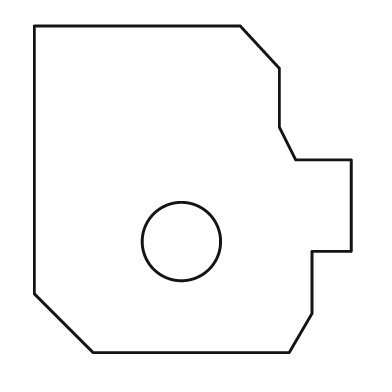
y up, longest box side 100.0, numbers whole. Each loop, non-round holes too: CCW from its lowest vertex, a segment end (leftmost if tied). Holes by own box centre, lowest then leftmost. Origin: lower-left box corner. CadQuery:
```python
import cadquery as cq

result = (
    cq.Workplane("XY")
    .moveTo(18.0, 0.0)
    .lineTo(78.0, 0.0)
    .lineTo(85.0, 12.0)
    .lineTo(85.0, 31.0)
    .lineTo(97.0, 31.0)
    .lineTo(97.0, 59.0)
    .lineTo(80.0, 59.0)
    .lineTo(75.0, 69.0)
    .lineTo(75.0, 87.0)
    .lineTo(63.0, 100.0)
    .lineTo(0.0, 100.0)
    .lineTo(0.0, 18.0)
    .close()
    .moveTo(45.0, 34.0)
    .circle(12.0)
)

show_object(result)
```